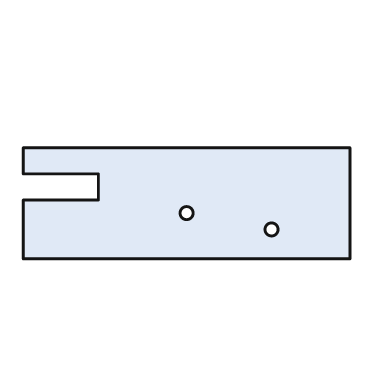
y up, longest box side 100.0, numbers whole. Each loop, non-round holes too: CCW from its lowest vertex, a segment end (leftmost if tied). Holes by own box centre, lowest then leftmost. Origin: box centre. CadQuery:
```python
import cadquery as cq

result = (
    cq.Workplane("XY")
    .moveTo(-50.0, -17.0)
    .lineTo(50.0, -17.0)
    .lineTo(50.0, 17.0)
    .lineTo(-50.0, 17.0)
    .lineTo(-50.0, 9.0)
    .lineTo(-27.0, 9.0)
    .lineTo(-27.0, 1.0)
    .lineTo(-50.0, 1.0)
    .close()
    .moveTo(26.0, -8.0)
    .circle(2.0)
    .moveTo(0.0, -3.0)
    .circle(2.0)
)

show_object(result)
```